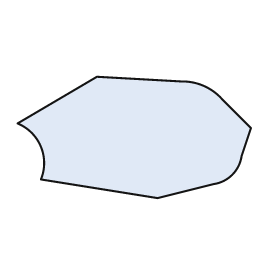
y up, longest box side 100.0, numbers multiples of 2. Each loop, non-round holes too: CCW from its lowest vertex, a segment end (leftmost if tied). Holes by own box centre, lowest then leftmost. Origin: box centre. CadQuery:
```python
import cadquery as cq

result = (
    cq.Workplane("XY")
    .moveTo(10.0, -26.0)
    .lineTo(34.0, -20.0)
    .threePointArc((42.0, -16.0), (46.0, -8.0))
    .lineTo(50.0, 4.0)
    .lineTo(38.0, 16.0)
    .threePointArc((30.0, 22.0), (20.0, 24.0))
    .lineTo(-16.0, 26.0)
    .lineTo(-50.0, 6.0)
    .threePointArc((-40.0, -4.0), (-40.0, -18.0))
    .close()
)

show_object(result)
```